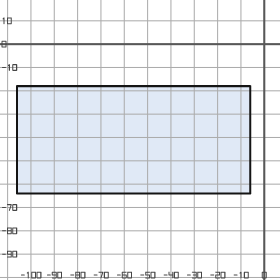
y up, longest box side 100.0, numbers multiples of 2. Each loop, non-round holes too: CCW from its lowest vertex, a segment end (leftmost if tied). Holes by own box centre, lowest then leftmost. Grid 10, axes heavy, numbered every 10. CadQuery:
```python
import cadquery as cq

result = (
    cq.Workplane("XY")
    .moveTo(-106.0, -64.0)
    .lineTo(-6.0, -64.0)
    .lineTo(-6.0, -18.0)
    .lineTo(-106.0, -18.0)
    .close()
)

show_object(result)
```